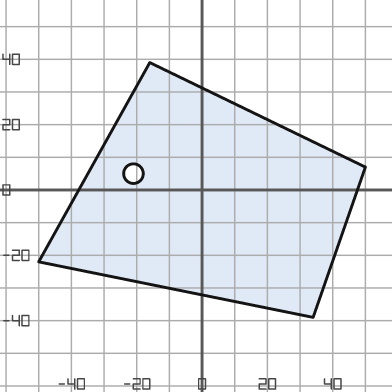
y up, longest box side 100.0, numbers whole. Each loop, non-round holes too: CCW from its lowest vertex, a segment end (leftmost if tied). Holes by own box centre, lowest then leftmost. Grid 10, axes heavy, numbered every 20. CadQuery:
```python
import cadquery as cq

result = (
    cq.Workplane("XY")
    .moveTo(34.0, -39.0)
    .lineTo(50.0, 7.0)
    .lineTo(-16.0, 39.0)
    .lineTo(-50.0, -22.0)
    .close()
    .moveTo(-21.0, 5.0)
    .circle(3.0)
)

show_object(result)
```